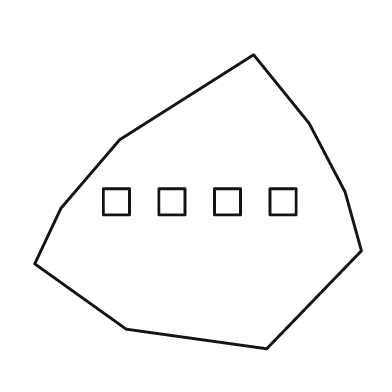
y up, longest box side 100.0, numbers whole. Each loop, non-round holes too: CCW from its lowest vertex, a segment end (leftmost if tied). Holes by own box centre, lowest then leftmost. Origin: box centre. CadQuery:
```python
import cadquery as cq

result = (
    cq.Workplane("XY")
    .moveTo(21.0, -45.0)
    .lineTo(50.0, -15.0)
    .lineTo(45.0, 3.0)
    .lineTo(34.0, 24.0)
    .lineTo(17.0, 45.0)
    .lineTo(-24.0, 19.0)
    .lineTo(-42.0, -2.0)
    .lineTo(-50.0, -19.0)
    .lineTo(-22.0, -39.0)
    .close()
    .moveTo(-29.0, -4.0)
    .lineTo(-21.0, -4.0)
    .lineTo(-21.0, 4.0)
    .lineTo(-29.0, 4.0)
    .close()
    .moveTo(-12.0, -4.0)
    .lineTo(-4.0, -4.0)
    .lineTo(-4.0, 4.0)
    .lineTo(-12.0, 4.0)
    .close()
    .moveTo(5.0, -4.0)
    .lineTo(13.0, -4.0)
    .lineTo(13.0, 4.0)
    .lineTo(5.0, 4.0)
    .close()
    .moveTo(22.0, -4.0)
    .lineTo(30.0, -4.0)
    .lineTo(30.0, 4.0)
    .lineTo(22.0, 4.0)
    .close()
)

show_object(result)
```